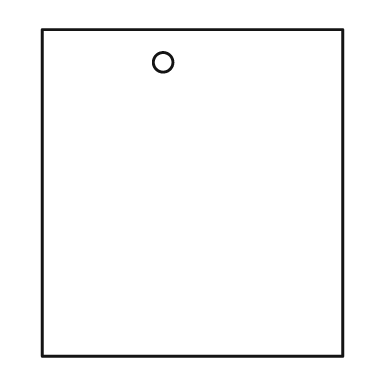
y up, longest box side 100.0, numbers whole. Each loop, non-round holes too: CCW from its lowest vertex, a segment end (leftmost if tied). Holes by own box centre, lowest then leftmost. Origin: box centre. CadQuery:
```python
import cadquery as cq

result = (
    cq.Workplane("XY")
    .moveTo(-46.0, -50.0)
    .lineTo(46.0, -50.0)
    .lineTo(46.0, 50.0)
    .lineTo(-46.0, 50.0)
    .close()
    .moveTo(-9.0, 40.0)
    .circle(3.0)
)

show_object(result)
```